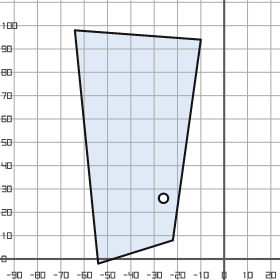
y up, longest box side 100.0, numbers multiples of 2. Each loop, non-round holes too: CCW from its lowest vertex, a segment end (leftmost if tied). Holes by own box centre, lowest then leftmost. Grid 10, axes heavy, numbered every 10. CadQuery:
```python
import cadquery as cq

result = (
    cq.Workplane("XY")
    .moveTo(-54.0, -2.0)
    .lineTo(-22.0, 8.0)
    .lineTo(-10.0, 94.0)
    .lineTo(-64.0, 98.0)
    .close()
    .moveTo(-26.0, 26.0)
    .circle(2.0)
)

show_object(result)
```